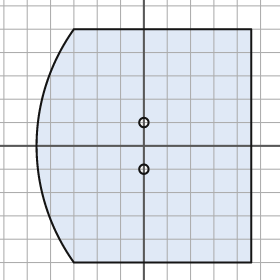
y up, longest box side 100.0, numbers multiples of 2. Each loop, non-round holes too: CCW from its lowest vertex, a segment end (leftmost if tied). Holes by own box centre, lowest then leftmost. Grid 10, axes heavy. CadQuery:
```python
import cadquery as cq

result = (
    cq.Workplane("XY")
    .moveTo(-30.0, -50.0)
    .lineTo(46.0, -50.0)
    .lineTo(46.0, 50.0)
    .lineTo(-30.0, 50.0)
    .threePointArc((-46.0, 0.0), (-30.0, -50.0))
    .close()
    .moveTo(0.0, -10.0)
    .circle(2.0)
    .moveTo(0.0, 10.0)
    .circle(2.0)
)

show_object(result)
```